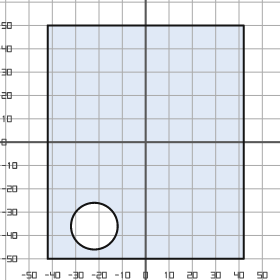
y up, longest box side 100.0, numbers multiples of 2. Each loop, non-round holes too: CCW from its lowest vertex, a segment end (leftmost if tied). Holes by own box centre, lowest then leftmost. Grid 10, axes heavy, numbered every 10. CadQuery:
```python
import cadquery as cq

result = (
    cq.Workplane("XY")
    .moveTo(-42.0, -50.0)
    .lineTo(42.0, -50.0)
    .lineTo(42.0, 50.0)
    .lineTo(-42.0, 50.0)
    .close()
    .moveTo(-22.0, -36.0)
    .circle(10.0)
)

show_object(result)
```